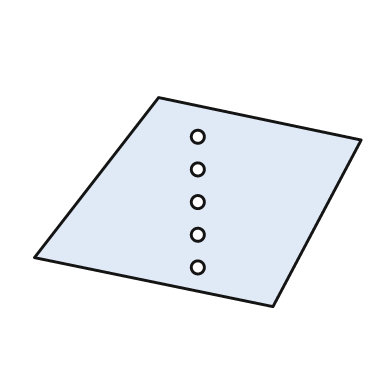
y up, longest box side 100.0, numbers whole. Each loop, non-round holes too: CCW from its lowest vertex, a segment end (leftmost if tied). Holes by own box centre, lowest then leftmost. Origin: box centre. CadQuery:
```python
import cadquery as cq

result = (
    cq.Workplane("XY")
    .moveTo(23.0, -32.0)
    .lineTo(50.0, 19.0)
    .lineTo(-12.0, 32.0)
    .lineTo(-50.0, -17.0)
    .close()
    .moveTo(0.0, -20.0)
    .circle(2.0)
    .moveTo(0.0, -10.0)
    .circle(2.0)
    .moveTo(0.0, 0.0)
    .circle(2.0)
    .moveTo(0.0, 10.0)
    .circle(2.0)
    .moveTo(0.0, 20.0)
    .circle(2.0)
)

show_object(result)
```